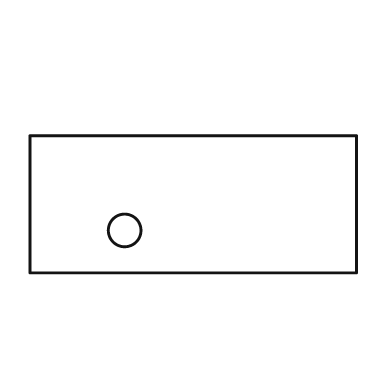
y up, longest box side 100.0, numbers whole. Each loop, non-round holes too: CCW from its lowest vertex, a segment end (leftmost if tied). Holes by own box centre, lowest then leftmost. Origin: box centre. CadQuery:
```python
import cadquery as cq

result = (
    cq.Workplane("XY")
    .moveTo(-50.0, -21.0)
    .lineTo(50.0, -21.0)
    .lineTo(50.0, 21.0)
    .lineTo(-50.0, 21.0)
    .close()
    .moveTo(-21.0, -8.0)
    .circle(5.0)
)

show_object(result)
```